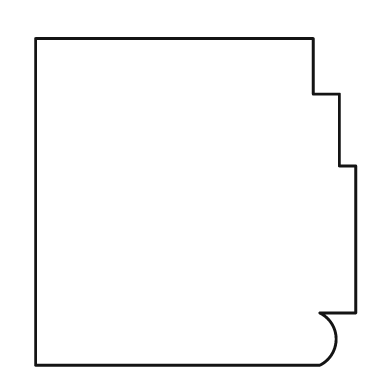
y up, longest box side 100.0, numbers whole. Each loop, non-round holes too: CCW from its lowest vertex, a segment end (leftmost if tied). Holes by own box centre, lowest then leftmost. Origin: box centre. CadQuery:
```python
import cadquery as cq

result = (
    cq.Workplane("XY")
    .moveTo(-49.0, -50.0)
    .lineTo(38.0, -50.0)
    .threePointArc((43.0, -42.0), (38.0, -34.0))
    .lineTo(49.0, -34.0)
    .lineTo(49.0, 11.0)
    .lineTo(44.0, 11.0)
    .lineTo(44.0, 33.0)
    .lineTo(36.0, 33.0)
    .lineTo(36.0, 50.0)
    .lineTo(-49.0, 50.0)
    .close()
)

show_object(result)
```